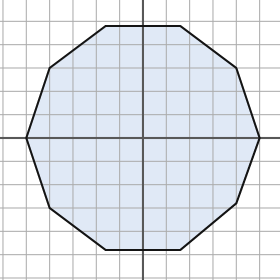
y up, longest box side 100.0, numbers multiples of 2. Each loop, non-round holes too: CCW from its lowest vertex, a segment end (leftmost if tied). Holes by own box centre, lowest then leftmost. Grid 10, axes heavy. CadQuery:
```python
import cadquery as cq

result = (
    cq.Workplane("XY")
    .moveTo(-16.0, -48.0)
    .lineTo(16.0, -48.0)
    .lineTo(40.0, -28.0)
    .lineTo(50.0, 0.0)
    .lineTo(40.0, 30.0)
    .lineTo(16.0, 48.0)
    .lineTo(-16.0, 48.0)
    .lineTo(-40.0, 30.0)
    .lineTo(-50.0, 0.0)
    .lineTo(-40.0, -30.0)
    .close()
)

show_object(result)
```